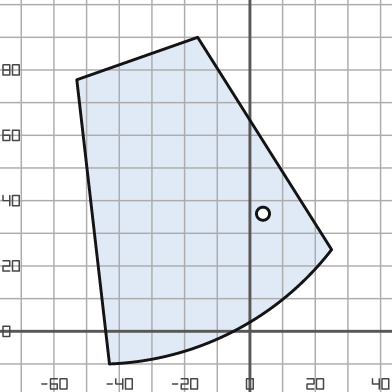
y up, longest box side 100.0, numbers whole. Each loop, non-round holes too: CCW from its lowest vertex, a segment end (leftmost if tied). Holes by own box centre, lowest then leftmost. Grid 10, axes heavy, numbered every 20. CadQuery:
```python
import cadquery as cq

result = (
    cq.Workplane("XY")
    .moveTo(-43.0, -10.0)
    .threePointArc((-5.0, 0.0), (25.0, 25.0))
    .lineTo(-16.0, 90.0)
    .lineTo(-53.0, 77.0)
    .close()
    .moveTo(4.0, 36.0)
    .circle(2.0)
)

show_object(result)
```